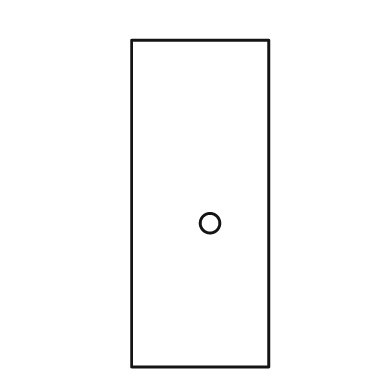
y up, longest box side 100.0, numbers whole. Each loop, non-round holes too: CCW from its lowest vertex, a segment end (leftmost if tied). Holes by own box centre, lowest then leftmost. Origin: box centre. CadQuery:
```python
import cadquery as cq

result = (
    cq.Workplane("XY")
    .moveTo(-21.0, -50.0)
    .lineTo(21.0, -50.0)
    .lineTo(21.0, 50.0)
    .lineTo(-21.0, 50.0)
    .close()
    .moveTo(3.0, -6.0)
    .circle(3.0)
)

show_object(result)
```